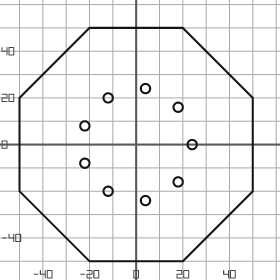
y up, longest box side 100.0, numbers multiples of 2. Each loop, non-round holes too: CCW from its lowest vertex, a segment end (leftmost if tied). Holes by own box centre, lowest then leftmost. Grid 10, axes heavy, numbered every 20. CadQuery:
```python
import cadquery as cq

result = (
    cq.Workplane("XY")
    .moveTo(-20.0, -50.0)
    .lineTo(20.0, -50.0)
    .lineTo(50.0, -20.0)
    .lineTo(50.0, 20.0)
    .lineTo(20.0, 50.0)
    .lineTo(-20.0, 50.0)
    .lineTo(-50.0, 20.0)
    .lineTo(-50.0, -20.0)
    .close()
    .moveTo(4.0, -24.0)
    .circle(2.0)
    .moveTo(-12.0, -20.0)
    .circle(2.0)
    .moveTo(18.0, -16.0)
    .circle(2.0)
    .moveTo(-22.0, -8.0)
    .circle(2.0)
    .moveTo(24.0, 0.0)
    .circle(2.0)
    .moveTo(-22.0, 8.0)
    .circle(2.0)
    .moveTo(18.0, 16.0)
    .circle(2.0)
    .moveTo(-12.0, 20.0)
    .circle(2.0)
    .moveTo(4.0, 24.0)
    .circle(2.0)
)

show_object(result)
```